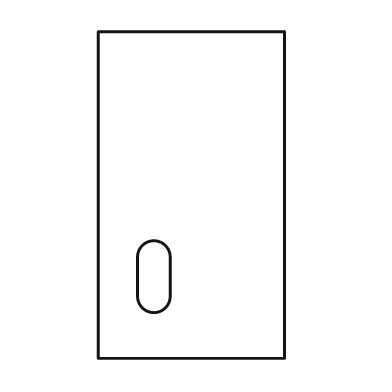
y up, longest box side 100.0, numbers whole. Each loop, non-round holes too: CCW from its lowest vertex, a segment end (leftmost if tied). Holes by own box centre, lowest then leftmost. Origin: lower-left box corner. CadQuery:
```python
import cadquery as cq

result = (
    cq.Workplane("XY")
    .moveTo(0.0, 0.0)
    .lineTo(57.0, 0.0)
    .lineTo(57.0, 100.0)
    .lineTo(0.0, 100.0)
    .close()
    .moveTo(12.0, 19.0)
    .threePointArc((17.0, 14.0), (22.0, 19.0))
    .lineTo(22.0, 31.0)
    .threePointArc((17.0, 36.0), (12.0, 31.0))
    .close()
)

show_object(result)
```